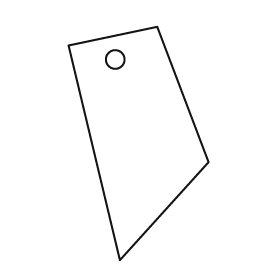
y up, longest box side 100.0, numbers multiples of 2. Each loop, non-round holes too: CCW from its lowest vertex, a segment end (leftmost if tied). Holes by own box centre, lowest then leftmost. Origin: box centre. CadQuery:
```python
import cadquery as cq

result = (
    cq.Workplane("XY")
    .moveTo(-8.0, -50.0)
    .lineTo(30.0, -8.0)
    .lineTo(8.0, 50.0)
    .lineTo(-30.0, 42.0)
    .close()
    .moveTo(-10.0, 36.0)
    .circle(4.0)
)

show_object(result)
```